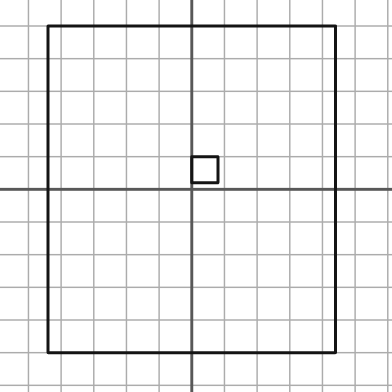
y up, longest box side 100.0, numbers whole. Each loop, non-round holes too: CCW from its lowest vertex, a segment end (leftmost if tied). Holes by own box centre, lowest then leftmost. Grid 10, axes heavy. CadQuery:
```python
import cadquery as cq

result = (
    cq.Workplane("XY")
    .moveTo(-44.0, -50.0)
    .lineTo(44.0, -50.0)
    .lineTo(44.0, 50.0)
    .lineTo(-44.0, 50.0)
    .close()
    .moveTo(0.0, 2.0)
    .lineTo(8.0, 2.0)
    .lineTo(8.0, 10.0)
    .lineTo(0.0, 10.0)
    .close()
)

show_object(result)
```